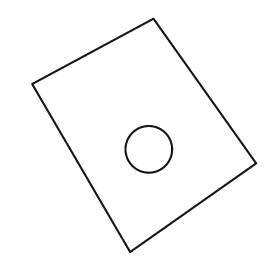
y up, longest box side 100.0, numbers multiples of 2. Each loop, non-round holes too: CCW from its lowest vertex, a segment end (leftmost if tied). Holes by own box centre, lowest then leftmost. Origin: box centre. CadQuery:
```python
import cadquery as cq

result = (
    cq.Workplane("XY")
    .moveTo(-6.0, -50.0)
    .lineTo(48.0, -12.0)
    .lineTo(4.0, 50.0)
    .lineTo(-48.0, 22.0)
    .close()
    .moveTo(2.0, -6.0)
    .circle(10.0)
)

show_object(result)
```